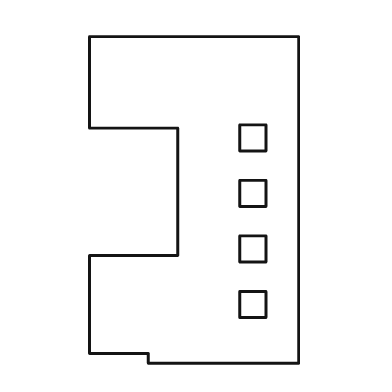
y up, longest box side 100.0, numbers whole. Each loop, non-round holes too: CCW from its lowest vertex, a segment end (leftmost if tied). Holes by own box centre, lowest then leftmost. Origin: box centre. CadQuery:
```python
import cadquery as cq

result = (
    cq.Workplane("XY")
    .moveTo(-14.0, -50.0)
    .lineTo(32.0, -50.0)
    .lineTo(32.0, 50.0)
    .lineTo(-32.0, 50.0)
    .lineTo(-32.0, 22.0)
    .lineTo(-5.0, 22.0)
    .lineTo(-5.0, -17.0)
    .lineTo(-32.0, -17.0)
    .lineTo(-32.0, -47.0)
    .lineTo(-14.0, -47.0)
    .close()
    .moveTo(14.0, -36.0)
    .lineTo(22.0, -36.0)
    .lineTo(22.0, -28.0)
    .lineTo(14.0, -28.0)
    .close()
    .moveTo(14.0, -19.0)
    .lineTo(22.0, -19.0)
    .lineTo(22.0, -11.0)
    .lineTo(14.0, -11.0)
    .close()
    .moveTo(14.0, -2.0)
    .lineTo(22.0, -2.0)
    .lineTo(22.0, 6.0)
    .lineTo(14.0, 6.0)
    .close()
    .moveTo(14.0, 15.0)
    .lineTo(22.0, 15.0)
    .lineTo(22.0, 23.0)
    .lineTo(14.0, 23.0)
    .close()
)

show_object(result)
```